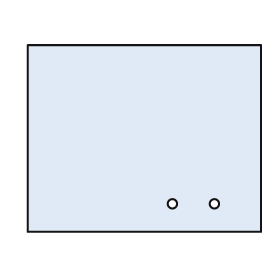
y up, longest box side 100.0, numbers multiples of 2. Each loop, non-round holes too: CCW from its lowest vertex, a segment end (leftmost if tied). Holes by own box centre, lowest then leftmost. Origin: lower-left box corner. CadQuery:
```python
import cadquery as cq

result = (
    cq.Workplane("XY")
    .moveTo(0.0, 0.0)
    .lineTo(100.0, 0.0)
    .lineTo(100.0, 80.0)
    .lineTo(0.0, 80.0)
    .close()
    .moveTo(62.0, 12.0)
    .circle(2.0)
    .moveTo(80.0, 12.0)
    .circle(2.0)
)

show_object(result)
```